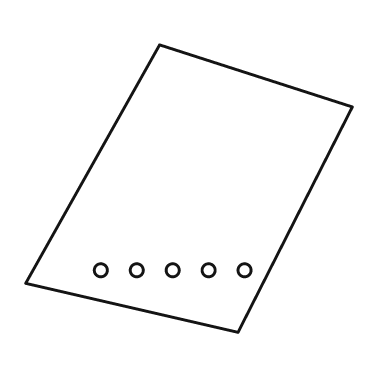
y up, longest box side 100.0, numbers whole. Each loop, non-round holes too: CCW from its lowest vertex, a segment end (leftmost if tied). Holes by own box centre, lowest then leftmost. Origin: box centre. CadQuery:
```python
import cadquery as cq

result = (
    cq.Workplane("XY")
    .moveTo(15.0, -44.0)
    .lineTo(50.0, 25.0)
    .lineTo(-9.0, 44.0)
    .lineTo(-50.0, -29.0)
    .close()
    .moveTo(-27.0, -25.0)
    .circle(2.0)
    .moveTo(-16.0, -25.0)
    .circle(2.0)
    .moveTo(-5.0, -25.0)
    .circle(2.0)
    .moveTo(6.0, -25.0)
    .circle(2.0)
    .moveTo(17.0, -25.0)
    .circle(2.0)
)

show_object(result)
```